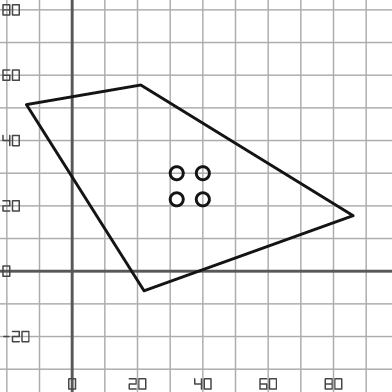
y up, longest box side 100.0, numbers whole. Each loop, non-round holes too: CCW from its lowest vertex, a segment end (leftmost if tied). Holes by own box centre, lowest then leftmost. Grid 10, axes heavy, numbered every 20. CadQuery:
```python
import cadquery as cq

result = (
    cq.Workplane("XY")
    .moveTo(22.0, -6.0)
    .lineTo(86.0, 17.0)
    .lineTo(21.0, 57.0)
    .lineTo(-14.0, 51.0)
    .close()
    .moveTo(32.0, 22.0)
    .circle(2.0)
    .moveTo(40.0, 22.0)
    .circle(2.0)
    .moveTo(32.0, 30.0)
    .circle(2.0)
    .moveTo(40.0, 30.0)
    .circle(2.0)
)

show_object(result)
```